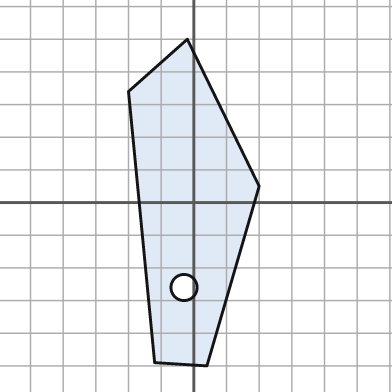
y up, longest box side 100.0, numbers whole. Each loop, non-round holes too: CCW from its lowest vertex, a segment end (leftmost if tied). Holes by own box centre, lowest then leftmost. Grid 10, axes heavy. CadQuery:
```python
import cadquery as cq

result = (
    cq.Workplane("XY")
    .moveTo(4.0, -50.0)
    .lineTo(20.0, 5.0)
    .lineTo(-2.0, 50.0)
    .lineTo(-20.0, 34.0)
    .lineTo(-12.0, -49.0)
    .close()
    .moveTo(-3.0, -26.0)
    .circle(4.0)
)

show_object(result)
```